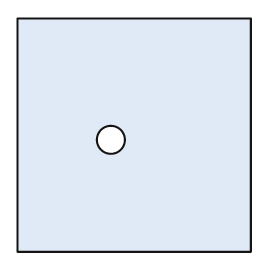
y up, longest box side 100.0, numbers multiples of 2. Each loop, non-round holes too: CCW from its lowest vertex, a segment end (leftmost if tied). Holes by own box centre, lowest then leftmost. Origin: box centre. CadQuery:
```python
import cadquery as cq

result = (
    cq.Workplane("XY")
    .moveTo(-50.0, -50.0)
    .lineTo(50.0, -50.0)
    .lineTo(50.0, 50.0)
    .lineTo(-50.0, 50.0)
    .close()
    .moveTo(-10.0, -2.0)
    .circle(6.0)
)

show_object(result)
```